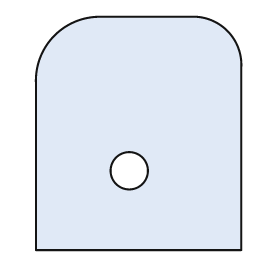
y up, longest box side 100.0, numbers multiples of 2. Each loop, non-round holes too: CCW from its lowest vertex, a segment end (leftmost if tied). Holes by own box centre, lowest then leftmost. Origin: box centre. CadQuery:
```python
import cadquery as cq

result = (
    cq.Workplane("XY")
    .moveTo(-44.0, -50.0)
    .lineTo(44.0, -50.0)
    .lineTo(44.0, 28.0)
    .threePointArc((38.0, 44.0), (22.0, 50.0))
    .lineTo(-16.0, 50.0)
    .threePointArc((-36.0, 42.0), (-44.0, 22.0))
    .close()
    .moveTo(-4.0, -16.0)
    .circle(8.0)
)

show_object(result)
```